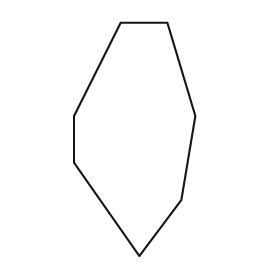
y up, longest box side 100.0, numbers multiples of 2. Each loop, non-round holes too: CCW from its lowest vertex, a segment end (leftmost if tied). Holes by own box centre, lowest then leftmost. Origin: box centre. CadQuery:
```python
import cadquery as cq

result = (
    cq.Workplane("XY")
    .moveTo(2.0, -50.0)
    .lineTo(20.0, -26.0)
    .lineTo(26.0, 10.0)
    .lineTo(14.0, 50.0)
    .lineTo(-6.0, 50.0)
    .lineTo(-26.0, 10.0)
    .lineTo(-26.0, -10.0)
    .close()
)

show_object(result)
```